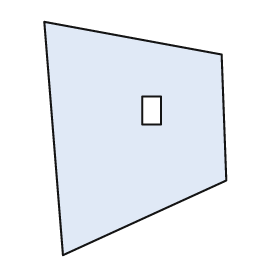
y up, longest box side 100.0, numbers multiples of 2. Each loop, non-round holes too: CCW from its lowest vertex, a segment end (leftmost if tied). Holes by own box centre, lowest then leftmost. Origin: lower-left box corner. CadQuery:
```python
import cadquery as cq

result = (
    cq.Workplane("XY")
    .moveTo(8.0, 0.0)
    .lineTo(78.0, 32.0)
    .lineTo(76.0, 86.0)
    .lineTo(0.0, 100.0)
    .close()
    .moveTo(42.0, 56.0)
    .lineTo(50.0, 56.0)
    .lineTo(50.0, 68.0)
    .lineTo(42.0, 68.0)
    .close()
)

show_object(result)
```